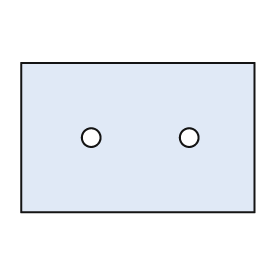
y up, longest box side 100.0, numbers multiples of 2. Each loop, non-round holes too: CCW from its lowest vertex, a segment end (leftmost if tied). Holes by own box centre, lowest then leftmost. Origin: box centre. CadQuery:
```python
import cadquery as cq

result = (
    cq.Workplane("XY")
    .moveTo(-50.0, -32.0)
    .lineTo(50.0, -32.0)
    .lineTo(50.0, 32.0)
    .lineTo(-50.0, 32.0)
    .close()
    .moveTo(-20.0, 0.0)
    .circle(4.0)
    .moveTo(22.0, 0.0)
    .circle(4.0)
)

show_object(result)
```